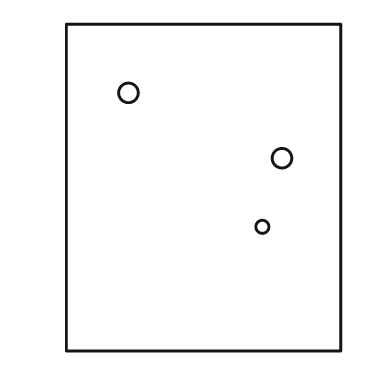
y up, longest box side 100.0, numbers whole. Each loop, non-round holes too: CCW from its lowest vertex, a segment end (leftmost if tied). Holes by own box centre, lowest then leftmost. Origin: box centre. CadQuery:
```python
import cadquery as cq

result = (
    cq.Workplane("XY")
    .moveTo(-42.0, -50.0)
    .lineTo(42.0, -50.0)
    .lineTo(42.0, 50.0)
    .lineTo(-42.0, 50.0)
    .close()
    .moveTo(18.0, -12.0)
    .circle(2.0)
    .moveTo(24.0, 9.0)
    .circle(3.0)
    .moveTo(-23.0, 29.0)
    .circle(3.0)
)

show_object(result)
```